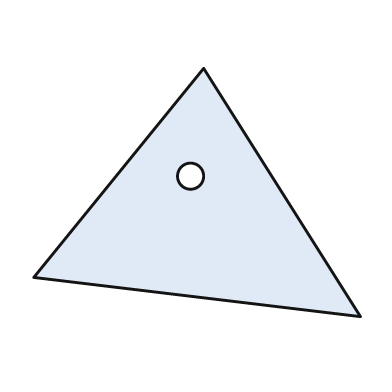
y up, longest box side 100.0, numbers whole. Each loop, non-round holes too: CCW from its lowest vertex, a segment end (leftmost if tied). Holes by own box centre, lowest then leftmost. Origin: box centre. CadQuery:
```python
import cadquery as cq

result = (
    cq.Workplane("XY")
    .moveTo(50.0, -38.0)
    .lineTo(2.0, 38.0)
    .lineTo(-50.0, -26.0)
    .close()
    .moveTo(-2.0, 5.0)
    .circle(4.0)
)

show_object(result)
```